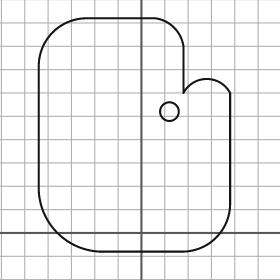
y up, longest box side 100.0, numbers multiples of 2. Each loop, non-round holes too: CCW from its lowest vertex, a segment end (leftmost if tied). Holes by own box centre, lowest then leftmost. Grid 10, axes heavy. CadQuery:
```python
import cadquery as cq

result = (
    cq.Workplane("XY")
    .moveTo(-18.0, -8.0)
    .lineTo(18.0, -8.0)
    .threePointArc((32.0, -2.0), (38.0, 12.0))
    .lineTo(38.0, 60.0)
    .threePointArc((28.0, 66.0), (18.0, 60.0))
    .lineTo(18.0, 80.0)
    .threePointArc((14.0, 88.0), (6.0, 92.0))
    .lineTo(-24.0, 92.0)
    .threePointArc((-38.0, 86.0), (-44.0, 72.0))
    .lineTo(-44.0, 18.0)
    .threePointArc((-36.0, 0.0), (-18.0, -8.0))
    .close()
    .moveTo(12.0, 52.0)
    .circle(4.0)
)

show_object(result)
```